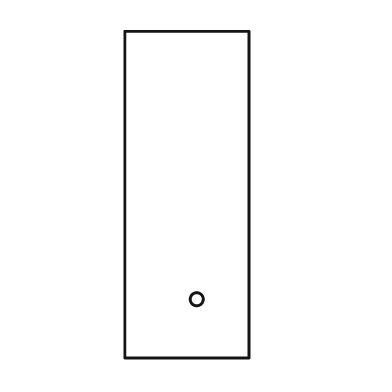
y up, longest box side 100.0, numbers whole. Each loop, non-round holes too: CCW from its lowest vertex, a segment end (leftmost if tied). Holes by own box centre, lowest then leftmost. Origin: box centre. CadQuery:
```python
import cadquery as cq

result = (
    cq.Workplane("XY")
    .moveTo(-19.0, -50.0)
    .lineTo(19.0, -50.0)
    .lineTo(19.0, 50.0)
    .lineTo(-19.0, 50.0)
    .close()
    .moveTo(3.0, -32.0)
    .circle(2.0)
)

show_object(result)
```